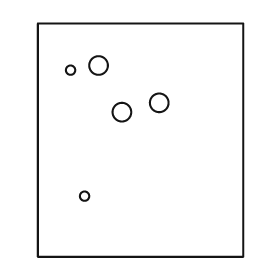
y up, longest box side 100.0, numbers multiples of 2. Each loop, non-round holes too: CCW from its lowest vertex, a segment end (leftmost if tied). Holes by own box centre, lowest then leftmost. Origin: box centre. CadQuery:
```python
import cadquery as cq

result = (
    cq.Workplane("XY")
    .moveTo(-44.0, -50.0)
    .lineTo(44.0, -50.0)
    .lineTo(44.0, 50.0)
    .lineTo(-44.0, 50.0)
    .close()
    .moveTo(-24.0, -24.0)
    .circle(2.0)
    .moveTo(-8.0, 12.0)
    .circle(4.0)
    .moveTo(8.0, 16.0)
    .circle(4.0)
    .moveTo(-30.0, 30.0)
    .circle(2.0)
    .moveTo(-18.0, 32.0)
    .circle(4.0)
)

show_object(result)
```